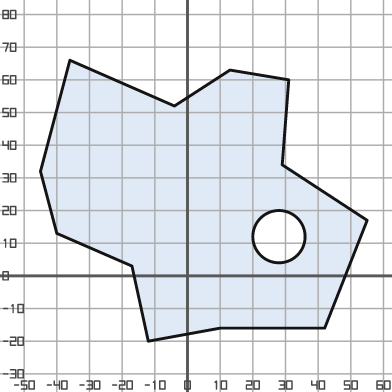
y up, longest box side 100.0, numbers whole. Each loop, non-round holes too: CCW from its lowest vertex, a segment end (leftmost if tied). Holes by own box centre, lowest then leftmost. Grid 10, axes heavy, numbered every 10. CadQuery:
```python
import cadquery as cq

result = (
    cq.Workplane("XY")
    .moveTo(-12.0, -20.0)
    .lineTo(10.0, -16.0)
    .lineTo(42.0, -16.0)
    .lineTo(55.0, 17.0)
    .lineTo(29.0, 34.0)
    .lineTo(31.0, 60.0)
    .lineTo(13.0, 63.0)
    .lineTo(-4.0, 52.0)
    .lineTo(-36.0, 66.0)
    .lineTo(-45.0, 32.0)
    .lineTo(-40.0, 13.0)
    .lineTo(-17.0, 3.0)
    .close()
    .moveTo(28.0, 12.0)
    .circle(8.0)
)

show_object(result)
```